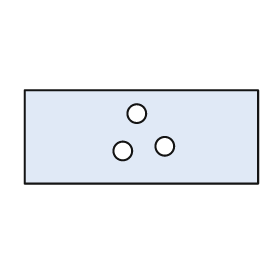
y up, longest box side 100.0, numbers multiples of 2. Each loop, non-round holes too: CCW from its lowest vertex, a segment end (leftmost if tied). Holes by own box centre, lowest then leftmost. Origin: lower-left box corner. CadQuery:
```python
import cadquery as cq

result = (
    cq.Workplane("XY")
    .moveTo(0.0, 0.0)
    .lineTo(100.0, 0.0)
    .lineTo(100.0, 40.0)
    .lineTo(0.0, 40.0)
    .close()
    .moveTo(42.0, 14.0)
    .circle(4.0)
    .moveTo(60.0, 16.0)
    .circle(4.0)
    .moveTo(48.0, 30.0)
    .circle(4.0)
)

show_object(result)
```